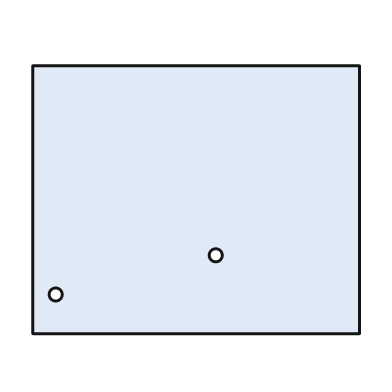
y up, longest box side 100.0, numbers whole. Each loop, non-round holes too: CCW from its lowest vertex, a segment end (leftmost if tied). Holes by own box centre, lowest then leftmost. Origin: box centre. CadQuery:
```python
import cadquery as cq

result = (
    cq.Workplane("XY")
    .moveTo(-50.0, -41.0)
    .lineTo(50.0, -41.0)
    .lineTo(50.0, 41.0)
    .lineTo(-50.0, 41.0)
    .close()
    .moveTo(-43.0, -29.0)
    .circle(2.0)
    .moveTo(6.0, -17.0)
    .circle(2.0)
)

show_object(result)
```